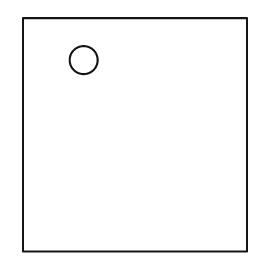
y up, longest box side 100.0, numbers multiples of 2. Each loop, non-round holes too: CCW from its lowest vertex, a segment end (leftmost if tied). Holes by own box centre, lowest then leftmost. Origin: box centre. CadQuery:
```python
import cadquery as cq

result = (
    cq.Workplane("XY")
    .moveTo(-48.0, -50.0)
    .lineTo(48.0, -50.0)
    .lineTo(48.0, 50.0)
    .lineTo(-48.0, 50.0)
    .close()
    .moveTo(-22.0, 32.0)
    .circle(6.0)
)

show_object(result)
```